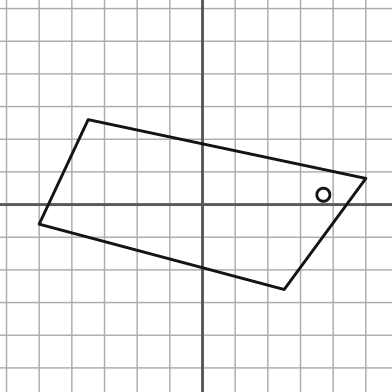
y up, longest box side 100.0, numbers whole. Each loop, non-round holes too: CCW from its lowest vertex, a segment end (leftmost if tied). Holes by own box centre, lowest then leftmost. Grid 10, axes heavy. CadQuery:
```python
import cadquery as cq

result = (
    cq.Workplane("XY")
    .moveTo(25.0, -26.0)
    .lineTo(50.0, 8.0)
    .lineTo(-35.0, 26.0)
    .lineTo(-50.0, -6.0)
    .close()
    .moveTo(37.0, 3.0)
    .circle(2.0)
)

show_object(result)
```